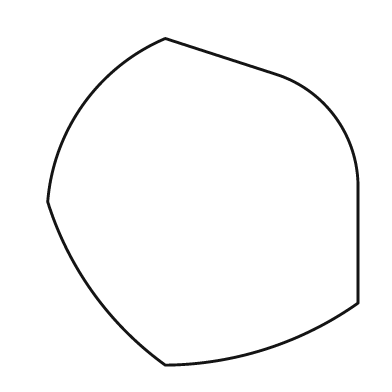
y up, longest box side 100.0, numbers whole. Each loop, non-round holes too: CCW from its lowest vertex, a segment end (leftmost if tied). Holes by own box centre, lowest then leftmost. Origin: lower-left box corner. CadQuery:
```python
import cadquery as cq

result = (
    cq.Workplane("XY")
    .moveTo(36.0, 0.0)
    .threePointArc((67.0, 5.0), (95.0, 19.0))
    .lineTo(95.0, 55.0)
    .threePointArc((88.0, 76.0), (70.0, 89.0))
    .lineTo(36.0, 100.0)
    .threePointArc((11.0, 80.0), (0.0, 50.0))
    .threePointArc((14.0, 22.0), (36.0, 0.0))
    .close()
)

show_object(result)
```